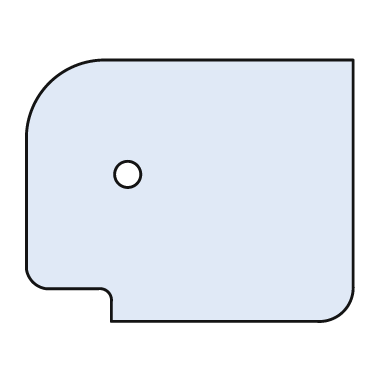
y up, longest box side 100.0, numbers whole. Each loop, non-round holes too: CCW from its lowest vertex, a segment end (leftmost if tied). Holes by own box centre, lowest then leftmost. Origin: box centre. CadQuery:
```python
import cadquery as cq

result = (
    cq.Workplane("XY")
    .moveTo(-24.0, -40.0)
    .lineTo(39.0, -40.0)
    .threePointArc((47.0, -37.0), (50.0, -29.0))
    .lineTo(50.0, 40.0)
    .lineTo(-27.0, 40.0)
    .threePointArc((-43.0, 33.0), (-50.0, 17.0))
    .lineTo(-50.0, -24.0)
    .threePointArc((-48.0, -28.0), (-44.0, -30.0))
    .lineTo(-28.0, -30.0)
    .threePointArc((-25.0, -31.0), (-24.0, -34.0))
    .close()
    .moveTo(-19.0, 5.0)
    .circle(4.0)
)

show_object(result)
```